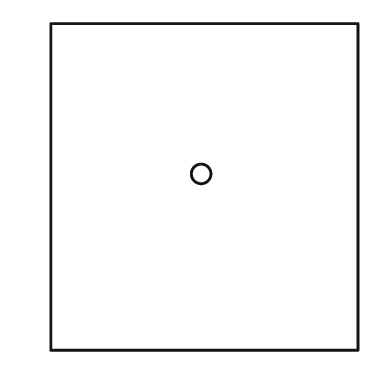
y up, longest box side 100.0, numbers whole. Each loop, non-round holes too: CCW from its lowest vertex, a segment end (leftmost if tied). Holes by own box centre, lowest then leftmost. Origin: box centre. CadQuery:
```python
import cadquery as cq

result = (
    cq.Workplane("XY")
    .moveTo(-47.0, -50.0)
    .lineTo(47.0, -50.0)
    .lineTo(47.0, 50.0)
    .lineTo(-47.0, 50.0)
    .close()
    .moveTo(-1.0, 4.0)
    .circle(3.0)
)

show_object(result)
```